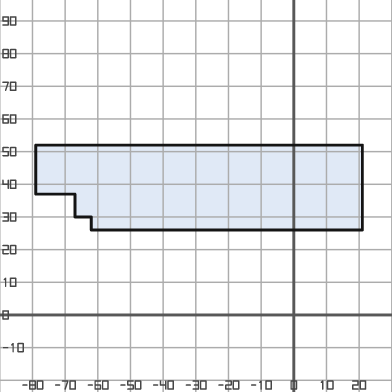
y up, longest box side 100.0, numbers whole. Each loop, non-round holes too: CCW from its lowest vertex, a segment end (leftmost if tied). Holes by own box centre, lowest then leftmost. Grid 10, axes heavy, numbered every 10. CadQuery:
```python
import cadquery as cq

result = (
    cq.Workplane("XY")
    .moveTo(-62.0, 26.0)
    .lineTo(21.0, 26.0)
    .lineTo(21.0, 52.0)
    .lineTo(-79.0, 52.0)
    .lineTo(-79.0, 37.0)
    .lineTo(-67.0, 37.0)
    .lineTo(-67.0, 30.0)
    .lineTo(-62.0, 30.0)
    .close()
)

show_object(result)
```